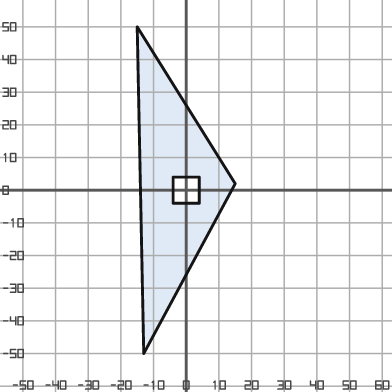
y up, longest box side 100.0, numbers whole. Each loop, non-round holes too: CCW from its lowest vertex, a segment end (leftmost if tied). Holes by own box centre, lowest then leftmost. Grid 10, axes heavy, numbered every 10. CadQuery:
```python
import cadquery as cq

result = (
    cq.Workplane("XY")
    .moveTo(-13.0, -50.0)
    .lineTo(15.0, 2.0)
    .lineTo(-15.0, 50.0)
    .close()
    .moveTo(-4.0, -4.0)
    .lineTo(4.0, -4.0)
    .lineTo(4.0, 4.0)
    .lineTo(-4.0, 4.0)
    .close()
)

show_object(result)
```